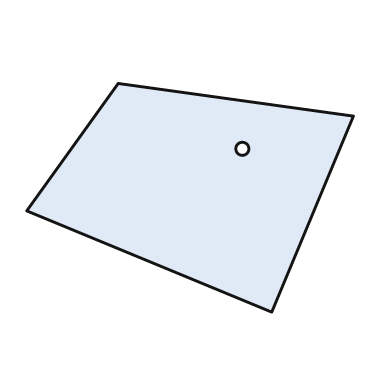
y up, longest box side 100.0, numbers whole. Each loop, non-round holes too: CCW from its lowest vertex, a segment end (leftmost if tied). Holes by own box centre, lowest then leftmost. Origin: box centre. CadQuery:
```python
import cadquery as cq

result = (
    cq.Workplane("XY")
    .moveTo(25.0, -35.0)
    .lineTo(50.0, 25.0)
    .lineTo(-22.0, 35.0)
    .lineTo(-50.0, -4.0)
    .close()
    .moveTo(16.0, 15.0)
    .circle(2.0)
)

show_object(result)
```